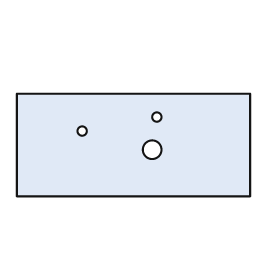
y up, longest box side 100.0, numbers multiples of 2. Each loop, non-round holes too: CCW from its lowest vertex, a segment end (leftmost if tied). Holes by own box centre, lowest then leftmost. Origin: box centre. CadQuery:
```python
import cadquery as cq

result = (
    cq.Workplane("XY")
    .moveTo(-50.0, -22.0)
    .lineTo(50.0, -22.0)
    .lineTo(50.0, 22.0)
    .lineTo(-50.0, 22.0)
    .close()
    .moveTo(8.0, -2.0)
    .circle(4.0)
    .moveTo(-22.0, 6.0)
    .circle(2.0)
    .moveTo(10.0, 12.0)
    .circle(2.0)
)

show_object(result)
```